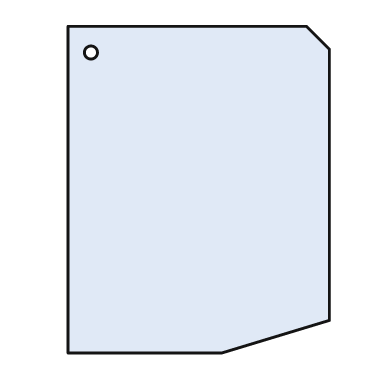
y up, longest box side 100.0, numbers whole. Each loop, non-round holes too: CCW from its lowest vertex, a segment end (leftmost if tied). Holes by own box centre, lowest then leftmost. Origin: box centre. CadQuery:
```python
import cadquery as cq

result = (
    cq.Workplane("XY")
    .moveTo(-40.0, -50.0)
    .lineTo(7.0, -50.0)
    .lineTo(40.0, -40.0)
    .lineTo(40.0, 43.0)
    .lineTo(33.0, 50.0)
    .lineTo(-40.0, 50.0)
    .close()
    .moveTo(-33.0, 42.0)
    .circle(2.0)
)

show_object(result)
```